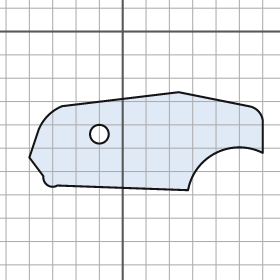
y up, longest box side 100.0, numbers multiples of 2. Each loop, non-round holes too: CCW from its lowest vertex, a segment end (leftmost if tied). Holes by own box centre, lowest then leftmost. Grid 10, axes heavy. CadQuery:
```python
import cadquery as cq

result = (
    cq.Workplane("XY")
    .moveTo(28.0, -68.0)
    .threePointArc((40.0, -52.0), (60.0, -52.0))
    .lineTo(60.0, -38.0)
    .threePointArc((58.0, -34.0), (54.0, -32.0))
    .lineTo(24.0, -26.0)
    .lineTo(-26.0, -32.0)
    .threePointArc((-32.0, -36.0), (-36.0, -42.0))
    .lineTo(-40.0, -54.0)
    .lineTo(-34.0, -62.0)
    .threePointArc((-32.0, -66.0), (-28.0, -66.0))
    .close()
    .moveTo(-10.0, -44.0)
    .circle(4.0)
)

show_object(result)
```